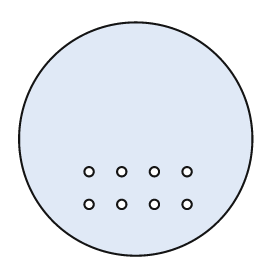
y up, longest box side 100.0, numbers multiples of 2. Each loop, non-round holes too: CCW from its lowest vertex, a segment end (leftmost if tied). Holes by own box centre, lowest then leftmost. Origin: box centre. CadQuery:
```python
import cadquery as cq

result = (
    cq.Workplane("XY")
    .moveTo(0.0, 0.0)
    .circle(50.0)
    .moveTo(-20.0, -28.0)
    .circle(2.0)
    .moveTo(-6.0, -28.0)
    .circle(2.0)
    .moveTo(8.0, -28.0)
    .circle(2.0)
    .moveTo(22.0, -28.0)
    .circle(2.0)
    .moveTo(-20.0, -14.0)
    .circle(2.0)
    .moveTo(-6.0, -14.0)
    .circle(2.0)
    .moveTo(8.0, -14.0)
    .circle(2.0)
    .moveTo(22.0, -14.0)
    .circle(2.0)
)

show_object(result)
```